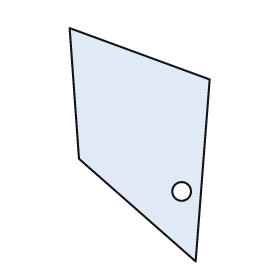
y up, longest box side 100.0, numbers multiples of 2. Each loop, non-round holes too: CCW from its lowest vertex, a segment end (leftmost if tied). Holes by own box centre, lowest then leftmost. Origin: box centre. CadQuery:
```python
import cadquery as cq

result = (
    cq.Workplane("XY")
    .moveTo(24.0, -50.0)
    .lineTo(30.0, 28.0)
    .lineTo(-30.0, 50.0)
    .lineTo(-26.0, -6.0)
    .close()
    .moveTo(18.0, -20.0)
    .circle(4.0)
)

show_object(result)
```